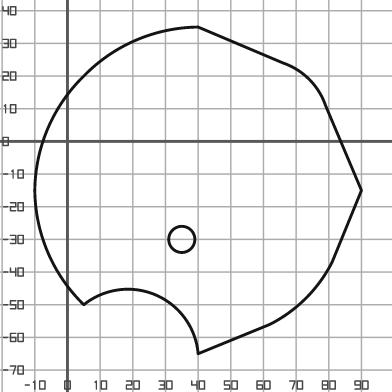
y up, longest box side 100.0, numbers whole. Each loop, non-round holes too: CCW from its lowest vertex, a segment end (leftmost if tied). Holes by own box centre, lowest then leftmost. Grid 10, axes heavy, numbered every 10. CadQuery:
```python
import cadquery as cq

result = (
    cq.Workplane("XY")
    .moveTo(40.0, -65.0)
    .lineTo(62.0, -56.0)
    .threePointArc((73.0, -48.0), (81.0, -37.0))
    .lineTo(90.0, -15.0)
    .lineTo(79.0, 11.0)
    .threePointArc((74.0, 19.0), (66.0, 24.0))
    .lineTo(40.0, 35.0)
    .threePointArc((21.0, 31.0), (5.0, 20.0))
    .threePointArc((-6.0, 4.0), (-10.0, -15.0))
    .threePointArc((-6.0, -34.0), (5.0, -50.0))
    .threePointArc((27.0, -47.0), (40.0, -65.0))
    .close()
    .moveTo(35.0, -30.0)
    .circle(4.0)
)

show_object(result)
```